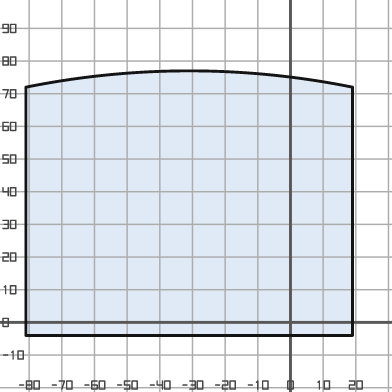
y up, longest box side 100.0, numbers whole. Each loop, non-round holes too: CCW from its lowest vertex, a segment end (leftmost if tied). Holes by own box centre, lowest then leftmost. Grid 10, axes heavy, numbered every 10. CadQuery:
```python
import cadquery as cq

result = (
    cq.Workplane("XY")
    .moveTo(-81.0, -4.0)
    .lineTo(19.0, -4.0)
    .lineTo(19.0, 72.0)
    .threePointArc((-31.0, 77.0), (-81.0, 72.0))
    .close()
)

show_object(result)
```